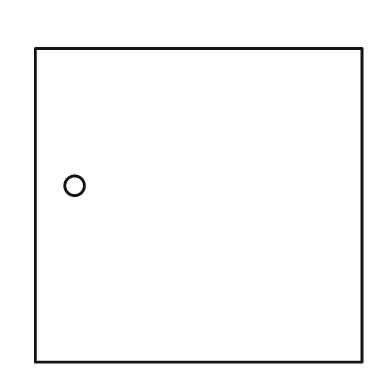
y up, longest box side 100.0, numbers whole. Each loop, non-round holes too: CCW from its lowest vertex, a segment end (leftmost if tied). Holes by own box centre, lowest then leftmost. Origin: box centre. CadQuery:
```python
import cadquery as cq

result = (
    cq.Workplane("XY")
    .moveTo(-50.0, -48.0)
    .lineTo(50.0, -48.0)
    .lineTo(50.0, 48.0)
    .lineTo(-50.0, 48.0)
    .close()
    .moveTo(-38.0, 6.0)
    .circle(3.0)
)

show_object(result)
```